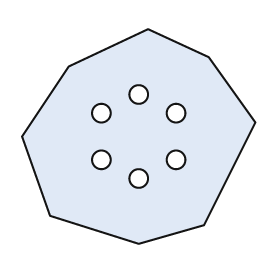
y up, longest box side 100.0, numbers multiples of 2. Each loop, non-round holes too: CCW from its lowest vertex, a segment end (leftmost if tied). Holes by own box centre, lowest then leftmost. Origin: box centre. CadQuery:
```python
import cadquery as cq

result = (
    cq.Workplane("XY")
    .moveTo(0.0, -46.0)
    .lineTo(28.0, -38.0)
    .lineTo(50.0, 6.0)
    .lineTo(30.0, 34.0)
    .lineTo(4.0, 46.0)
    .lineTo(-30.0, 30.0)
    .lineTo(-50.0, 0.0)
    .lineTo(-38.0, -34.0)
    .close()
    .moveTo(0.0, -18.0)
    .circle(4.0)
    .moveTo(-16.0, -10.0)
    .circle(4.0)
    .moveTo(16.0, -10.0)
    .circle(4.0)
    .moveTo(-16.0, 10.0)
    .circle(4.0)
    .moveTo(16.0, 10.0)
    .circle(4.0)
    .moveTo(0.0, 18.0)
    .circle(4.0)
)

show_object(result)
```